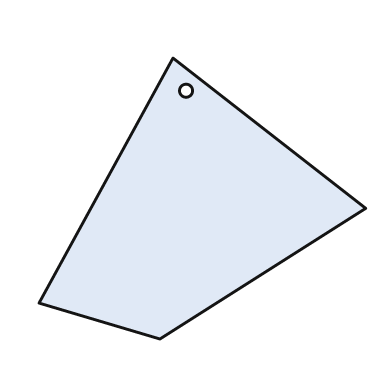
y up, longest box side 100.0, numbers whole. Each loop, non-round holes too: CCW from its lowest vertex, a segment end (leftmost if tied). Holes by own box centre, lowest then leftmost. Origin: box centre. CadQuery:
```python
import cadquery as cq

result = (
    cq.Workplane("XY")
    .moveTo(-13.0, -43.0)
    .lineTo(50.0, -3.0)
    .lineTo(-9.0, 43.0)
    .lineTo(-50.0, -32.0)
    .close()
    .moveTo(-5.0, 33.0)
    .circle(2.0)
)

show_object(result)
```